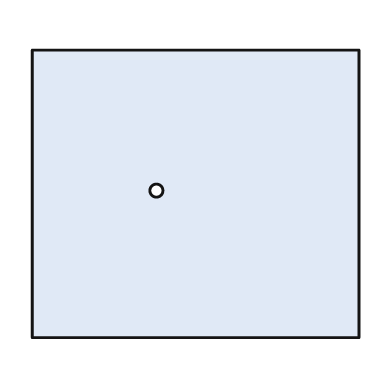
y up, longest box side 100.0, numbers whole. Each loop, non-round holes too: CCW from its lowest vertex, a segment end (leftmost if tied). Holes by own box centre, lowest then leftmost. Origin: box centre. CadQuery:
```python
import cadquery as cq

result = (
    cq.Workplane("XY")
    .moveTo(-50.0, -44.0)
    .lineTo(50.0, -44.0)
    .lineTo(50.0, 44.0)
    .lineTo(-50.0, 44.0)
    .close()
    .moveTo(-12.0, 1.0)
    .circle(2.0)
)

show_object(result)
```